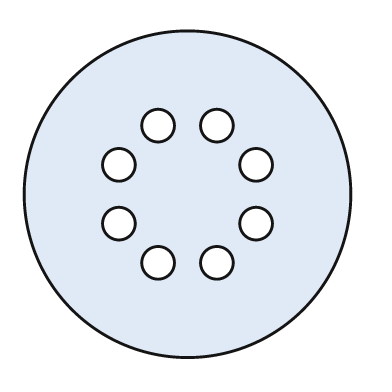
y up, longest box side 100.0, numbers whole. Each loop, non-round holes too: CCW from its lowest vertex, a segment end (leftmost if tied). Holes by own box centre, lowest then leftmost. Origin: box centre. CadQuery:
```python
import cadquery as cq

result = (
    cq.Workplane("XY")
    .moveTo(0.0, 0.0)
    .circle(50.0)
    .moveTo(-9.0, -21.0)
    .circle(5.0)
    .moveTo(9.0, -21.0)
    .circle(5.0)
    .moveTo(-21.0, -9.0)
    .circle(5.0)
    .moveTo(21.0, -9.0)
    .circle(5.0)
    .moveTo(-21.0, 9.0)
    .circle(5.0)
    .moveTo(21.0, 9.0)
    .circle(5.0)
    .moveTo(-9.0, 21.0)
    .circle(5.0)
    .moveTo(9.0, 21.0)
    .circle(5.0)
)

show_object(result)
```